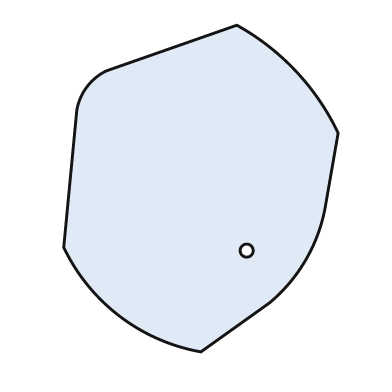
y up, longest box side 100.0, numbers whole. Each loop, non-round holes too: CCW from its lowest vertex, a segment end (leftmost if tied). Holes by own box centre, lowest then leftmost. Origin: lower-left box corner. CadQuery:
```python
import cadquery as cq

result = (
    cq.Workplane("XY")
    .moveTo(42.0, 0.0)
    .lineTo(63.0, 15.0)
    .threePointArc((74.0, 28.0), (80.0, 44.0))
    .lineTo(84.0, 67.0)
    .threePointArc((71.0, 86.0), (53.0, 100.0))
    .lineTo(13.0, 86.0)
    .threePointArc((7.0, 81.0), (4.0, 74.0))
    .lineTo(0.0, 32.0)
    .threePointArc((17.0, 11.0), (42.0, 0.0))
    .close()
    .moveTo(56.0, 31.0)
    .circle(2.0)
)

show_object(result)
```